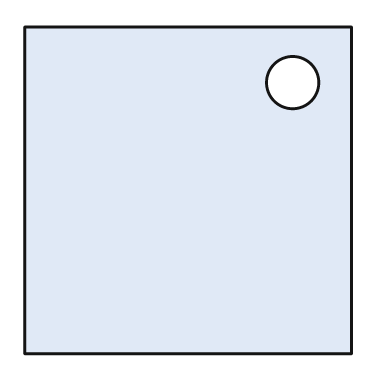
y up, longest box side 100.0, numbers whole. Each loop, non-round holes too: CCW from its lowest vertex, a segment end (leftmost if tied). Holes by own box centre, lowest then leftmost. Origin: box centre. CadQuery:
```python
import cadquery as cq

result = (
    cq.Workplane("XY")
    .moveTo(-50.0, -50.0)
    .lineTo(50.0, -50.0)
    .lineTo(50.0, 50.0)
    .lineTo(-50.0, 50.0)
    .close()
    .moveTo(32.0, 33.0)
    .circle(8.0)
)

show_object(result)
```